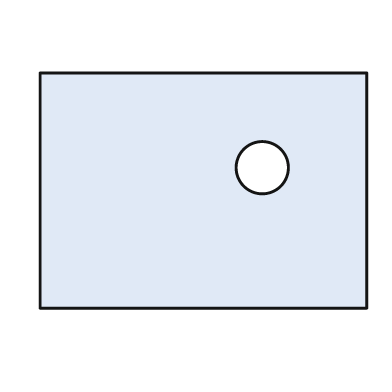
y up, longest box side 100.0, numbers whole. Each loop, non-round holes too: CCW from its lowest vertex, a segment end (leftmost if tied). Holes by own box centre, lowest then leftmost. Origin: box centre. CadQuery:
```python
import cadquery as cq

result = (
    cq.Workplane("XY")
    .moveTo(-50.0, -36.0)
    .lineTo(50.0, -36.0)
    .lineTo(50.0, 36.0)
    .lineTo(-50.0, 36.0)
    .close()
    .moveTo(18.0, 7.0)
    .circle(8.0)
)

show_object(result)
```